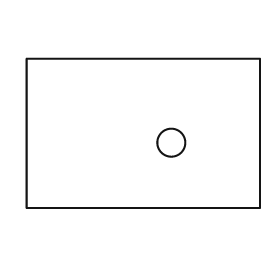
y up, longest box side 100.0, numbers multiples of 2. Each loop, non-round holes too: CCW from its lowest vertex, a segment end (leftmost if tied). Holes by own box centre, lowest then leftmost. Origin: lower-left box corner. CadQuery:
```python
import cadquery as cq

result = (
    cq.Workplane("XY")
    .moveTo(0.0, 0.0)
    .lineTo(100.0, 0.0)
    .lineTo(100.0, 64.0)
    .lineTo(0.0, 64.0)
    .close()
    .moveTo(62.0, 28.0)
    .circle(6.0)
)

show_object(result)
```